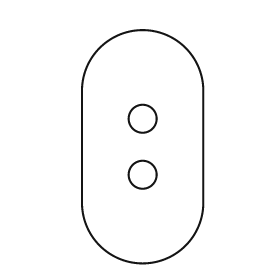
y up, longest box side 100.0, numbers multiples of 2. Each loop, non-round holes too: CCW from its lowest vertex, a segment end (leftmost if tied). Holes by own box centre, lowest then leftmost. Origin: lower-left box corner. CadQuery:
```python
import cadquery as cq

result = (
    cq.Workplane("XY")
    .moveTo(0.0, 26.0)
    .threePointArc((26.0, 0.0), (52.0, 26.0))
    .lineTo(52.0, 74.0)
    .threePointArc((26.0, 100.0), (0.0, 74.0))
    .close()
    .moveTo(26.0, 38.0)
    .circle(6.0)
    .moveTo(26.0, 62.0)
    .circle(6.0)
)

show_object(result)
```